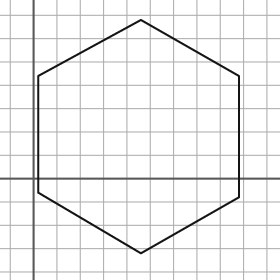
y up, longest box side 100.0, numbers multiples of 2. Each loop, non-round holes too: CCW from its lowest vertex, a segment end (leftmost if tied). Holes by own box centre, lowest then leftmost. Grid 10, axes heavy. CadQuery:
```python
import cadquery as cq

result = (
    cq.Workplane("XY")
    .moveTo(46.0, -32.0)
    .lineTo(88.0, -8.0)
    .lineTo(88.0, 44.0)
    .lineTo(46.0, 68.0)
    .lineTo(2.0, 44.0)
    .lineTo(2.0, -6.0)
    .close()
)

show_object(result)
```